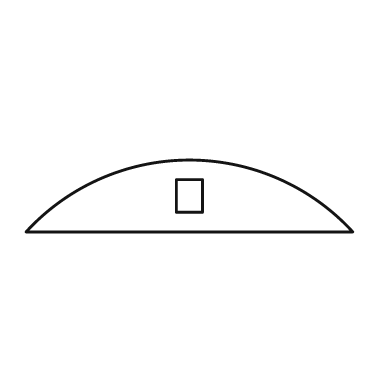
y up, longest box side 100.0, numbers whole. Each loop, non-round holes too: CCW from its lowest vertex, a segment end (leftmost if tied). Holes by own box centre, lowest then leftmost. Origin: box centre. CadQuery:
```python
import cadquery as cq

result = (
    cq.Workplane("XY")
    .moveTo(-50.0, -11.0)
    .lineTo(50.0, -11.0)
    .threePointArc((0.0, 11.0), (-50.0, -11.0))
    .close()
    .moveTo(-4.0, -5.0)
    .lineTo(4.0, -5.0)
    .lineTo(4.0, 5.0)
    .lineTo(-4.0, 5.0)
    .close()
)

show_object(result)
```